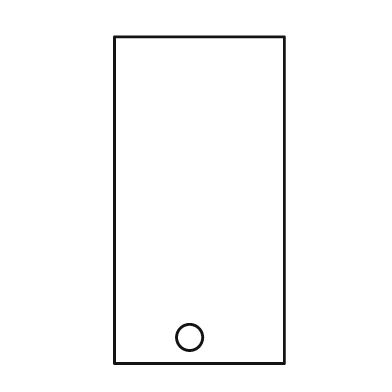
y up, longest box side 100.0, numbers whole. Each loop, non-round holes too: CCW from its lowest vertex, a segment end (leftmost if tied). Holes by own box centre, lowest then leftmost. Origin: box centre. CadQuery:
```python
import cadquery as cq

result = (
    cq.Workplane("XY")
    .moveTo(-26.0, -50.0)
    .lineTo(26.0, -50.0)
    .lineTo(26.0, 50.0)
    .lineTo(-26.0, 50.0)
    .close()
    .moveTo(-3.0, -42.0)
    .circle(4.0)
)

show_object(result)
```